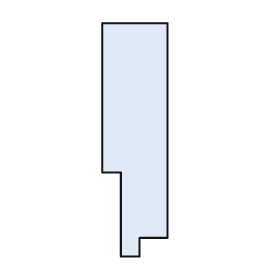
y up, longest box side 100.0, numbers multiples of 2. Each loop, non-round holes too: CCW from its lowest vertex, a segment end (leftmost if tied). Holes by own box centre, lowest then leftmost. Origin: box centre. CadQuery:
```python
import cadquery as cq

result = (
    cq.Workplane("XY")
    .moveTo(-6.0, -50.0)
    .lineTo(2.0, -50.0)
    .lineTo(2.0, -42.0)
    .lineTo(14.0, -42.0)
    .lineTo(14.0, 50.0)
    .lineTo(-14.0, 50.0)
    .lineTo(-14.0, -14.0)
    .lineTo(-6.0, -14.0)
    .close()
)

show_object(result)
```